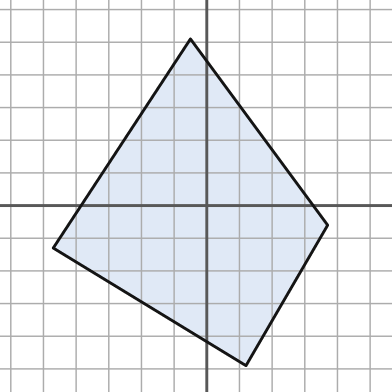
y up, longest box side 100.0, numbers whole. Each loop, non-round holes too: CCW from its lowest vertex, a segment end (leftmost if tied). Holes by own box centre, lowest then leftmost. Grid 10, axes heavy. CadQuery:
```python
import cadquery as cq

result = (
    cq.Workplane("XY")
    .moveTo(12.0, -49.0)
    .lineTo(37.0, -6.0)
    .lineTo(-5.0, 51.0)
    .lineTo(-47.0, -13.0)
    .close()
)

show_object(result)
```